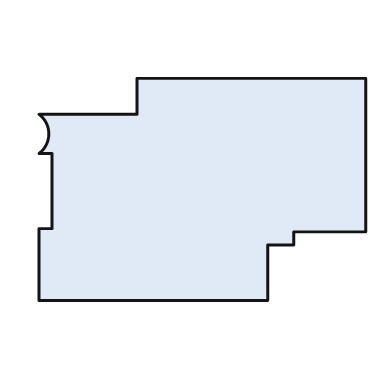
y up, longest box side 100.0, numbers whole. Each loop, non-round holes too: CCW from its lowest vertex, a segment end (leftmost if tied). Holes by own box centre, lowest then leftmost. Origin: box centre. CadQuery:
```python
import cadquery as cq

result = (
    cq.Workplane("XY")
    .moveTo(-50.0, -34.0)
    .lineTo(20.0, -34.0)
    .lineTo(20.0, -17.0)
    .lineTo(28.0, -17.0)
    .lineTo(28.0, -13.0)
    .lineTo(50.0, -13.0)
    .lineTo(50.0, 34.0)
    .lineTo(-20.0, 34.0)
    .lineTo(-20.0, 23.0)
    .lineTo(-50.0, 23.0)
    .threePointArc((-47.0, 17.0), (-50.0, 11.0))
    .lineTo(-46.0, 11.0)
    .lineTo(-46.0, -12.0)
    .lineTo(-50.0, -12.0)
    .close()
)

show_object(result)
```